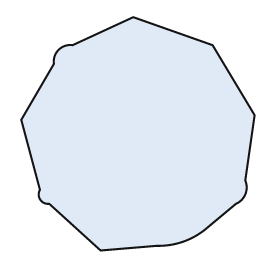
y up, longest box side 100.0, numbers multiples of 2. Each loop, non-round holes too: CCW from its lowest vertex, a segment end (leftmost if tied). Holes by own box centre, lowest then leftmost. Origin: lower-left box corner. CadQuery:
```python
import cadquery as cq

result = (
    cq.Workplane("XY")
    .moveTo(34.0, 0.0)
    .lineTo(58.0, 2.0)
    .threePointArc((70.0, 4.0), (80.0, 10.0))
    .lineTo(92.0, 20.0)
    .threePointArc((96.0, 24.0), (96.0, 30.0))
    .lineTo(100.0, 58.0)
    .lineTo(82.0, 88.0)
    .lineTo(48.0, 100.0)
    .lineTo(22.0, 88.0)
    .threePointArc((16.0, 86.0), (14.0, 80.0))
    .lineTo(0.0, 56.0)
    .lineTo(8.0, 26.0)
    .threePointArc((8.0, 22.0), (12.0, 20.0))
    .close()
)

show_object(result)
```